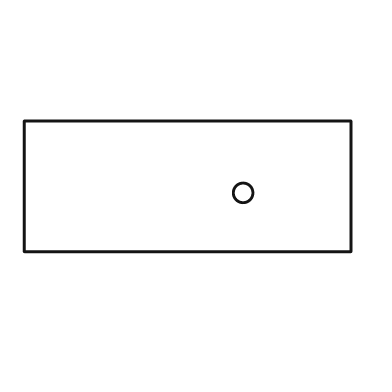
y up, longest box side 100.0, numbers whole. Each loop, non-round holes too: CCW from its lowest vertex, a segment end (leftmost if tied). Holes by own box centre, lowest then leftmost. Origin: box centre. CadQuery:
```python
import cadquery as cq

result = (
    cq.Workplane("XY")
    .moveTo(-50.0, -20.0)
    .lineTo(50.0, -20.0)
    .lineTo(50.0, 20.0)
    .lineTo(-50.0, 20.0)
    .close()
    .moveTo(17.0, -2.0)
    .circle(3.0)
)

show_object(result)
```